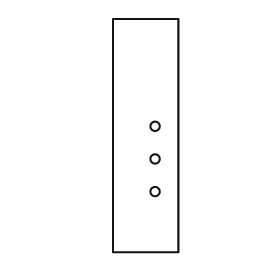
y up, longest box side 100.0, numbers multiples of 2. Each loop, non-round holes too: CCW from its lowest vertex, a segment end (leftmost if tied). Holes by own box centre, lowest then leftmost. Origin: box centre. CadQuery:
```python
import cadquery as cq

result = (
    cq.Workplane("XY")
    .moveTo(-14.0, -50.0)
    .lineTo(14.0, -50.0)
    .lineTo(14.0, 50.0)
    .lineTo(-14.0, 50.0)
    .close()
    .moveTo(4.0, -24.0)
    .circle(2.0)
    .moveTo(4.0, -10.0)
    .circle(2.0)
    .moveTo(4.0, 4.0)
    .circle(2.0)
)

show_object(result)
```